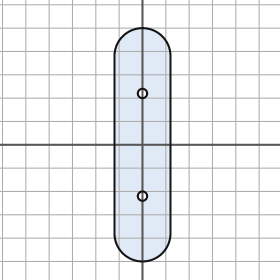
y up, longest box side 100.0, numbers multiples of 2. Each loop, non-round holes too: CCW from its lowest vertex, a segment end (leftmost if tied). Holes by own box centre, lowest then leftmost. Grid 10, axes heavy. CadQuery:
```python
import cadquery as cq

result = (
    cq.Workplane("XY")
    .moveTo(-12.0, -38.0)
    .threePointArc((0.0, -50.0), (12.0, -38.0))
    .lineTo(12.0, 38.0)
    .threePointArc((0.0, 50.0), (-12.0, 38.0))
    .close()
    .moveTo(0.0, -22.0)
    .circle(2.0)
    .moveTo(0.0, 22.0)
    .circle(2.0)
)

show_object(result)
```